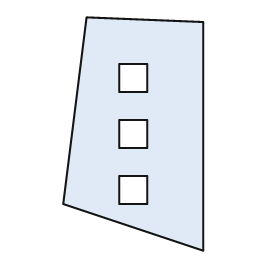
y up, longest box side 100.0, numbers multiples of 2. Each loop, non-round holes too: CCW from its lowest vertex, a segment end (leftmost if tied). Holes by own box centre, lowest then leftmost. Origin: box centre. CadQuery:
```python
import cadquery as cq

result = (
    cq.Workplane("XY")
    .moveTo(30.0, -50.0)
    .lineTo(30.0, 48.0)
    .lineTo(-20.0, 50.0)
    .lineTo(-30.0, -30.0)
    .close()
    .moveTo(-6.0, -30.0)
    .lineTo(6.0, -30.0)
    .lineTo(6.0, -18.0)
    .lineTo(-6.0, -18.0)
    .close()
    .moveTo(-6.0, -6.0)
    .lineTo(6.0, -6.0)
    .lineTo(6.0, 6.0)
    .lineTo(-6.0, 6.0)
    .close()
    .moveTo(-6.0, 18.0)
    .lineTo(6.0, 18.0)
    .lineTo(6.0, 30.0)
    .lineTo(-6.0, 30.0)
    .close()
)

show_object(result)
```